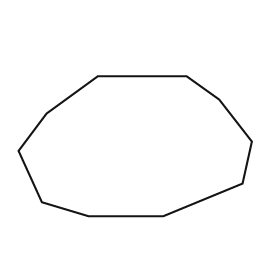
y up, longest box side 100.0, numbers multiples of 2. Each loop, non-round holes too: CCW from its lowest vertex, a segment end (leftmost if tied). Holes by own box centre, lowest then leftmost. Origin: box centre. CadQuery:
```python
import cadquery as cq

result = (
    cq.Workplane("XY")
    .moveTo(-20.0, -30.0)
    .lineTo(12.0, -30.0)
    .lineTo(46.0, -16.0)
    .lineTo(50.0, 2.0)
    .lineTo(36.0, 20.0)
    .lineTo(22.0, 30.0)
    .lineTo(-16.0, 30.0)
    .lineTo(-38.0, 14.0)
    .lineTo(-50.0, -2.0)
    .lineTo(-40.0, -24.0)
    .close()
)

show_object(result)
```